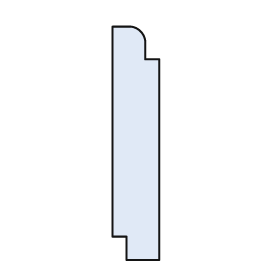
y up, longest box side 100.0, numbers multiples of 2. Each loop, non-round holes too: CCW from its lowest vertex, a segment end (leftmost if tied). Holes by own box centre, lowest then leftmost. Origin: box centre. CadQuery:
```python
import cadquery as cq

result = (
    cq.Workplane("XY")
    .moveTo(-4.0, -50.0)
    .lineTo(10.0, -50.0)
    .lineTo(10.0, 36.0)
    .lineTo(4.0, 36.0)
    .lineTo(4.0, 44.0)
    .threePointArc((2.0, 48.0), (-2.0, 50.0))
    .lineTo(-10.0, 50.0)
    .lineTo(-10.0, -40.0)
    .lineTo(-4.0, -40.0)
    .close()
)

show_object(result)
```